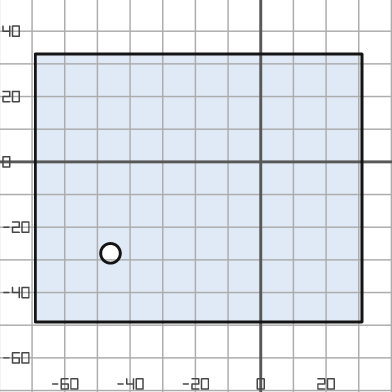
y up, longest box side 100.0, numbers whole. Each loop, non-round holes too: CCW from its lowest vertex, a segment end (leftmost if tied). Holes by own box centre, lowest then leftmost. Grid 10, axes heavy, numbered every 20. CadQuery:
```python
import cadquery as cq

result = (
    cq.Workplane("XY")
    .moveTo(-69.0, -49.0)
    .lineTo(31.0, -49.0)
    .lineTo(31.0, 33.0)
    .lineTo(-69.0, 33.0)
    .close()
    .moveTo(-46.0, -28.0)
    .circle(3.0)
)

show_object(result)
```